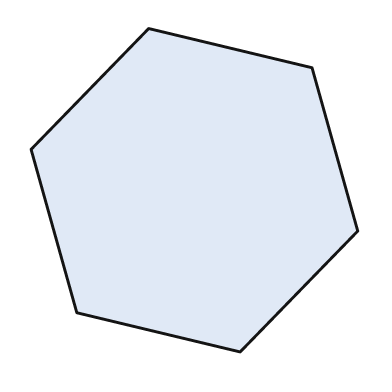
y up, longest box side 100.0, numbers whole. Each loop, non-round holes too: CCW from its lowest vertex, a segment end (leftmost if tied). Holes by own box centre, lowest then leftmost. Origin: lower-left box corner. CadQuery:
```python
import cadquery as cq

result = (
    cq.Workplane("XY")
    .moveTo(64.0, 0.0)
    .lineTo(100.0, 37.0)
    .lineTo(86.0, 87.0)
    .lineTo(36.0, 99.0)
    .lineTo(0.0, 62.0)
    .lineTo(14.0, 12.0)
    .close()
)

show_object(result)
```